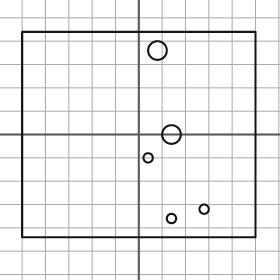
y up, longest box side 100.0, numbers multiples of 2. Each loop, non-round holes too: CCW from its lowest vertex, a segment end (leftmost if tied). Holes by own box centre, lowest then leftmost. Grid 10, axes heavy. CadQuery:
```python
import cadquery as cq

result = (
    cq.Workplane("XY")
    .moveTo(-50.0, -44.0)
    .lineTo(50.0, -44.0)
    .lineTo(50.0, 44.0)
    .lineTo(-50.0, 44.0)
    .close()
    .moveTo(14.0, -36.0)
    .circle(2.0)
    .moveTo(28.0, -32.0)
    .circle(2.0)
    .moveTo(4.0, -10.0)
    .circle(2.0)
    .moveTo(14.0, 0.0)
    .circle(4.0)
    .moveTo(8.0, 36.0)
    .circle(4.0)
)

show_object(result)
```